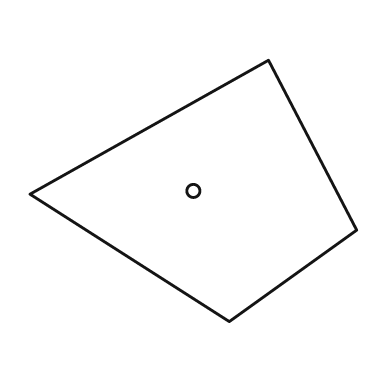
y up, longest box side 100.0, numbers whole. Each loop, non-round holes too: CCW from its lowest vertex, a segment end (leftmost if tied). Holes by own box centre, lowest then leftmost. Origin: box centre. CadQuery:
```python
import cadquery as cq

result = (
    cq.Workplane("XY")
    .moveTo(11.0, -40.0)
    .lineTo(50.0, -12.0)
    .lineTo(23.0, 40.0)
    .lineTo(-50.0, -1.0)
    .close()
    .moveTo(0.0, 0.0)
    .circle(2.0)
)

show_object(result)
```